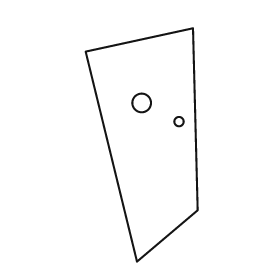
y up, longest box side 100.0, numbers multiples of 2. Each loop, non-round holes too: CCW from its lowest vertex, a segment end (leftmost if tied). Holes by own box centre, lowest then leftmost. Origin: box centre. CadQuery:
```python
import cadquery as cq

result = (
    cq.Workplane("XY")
    .moveTo(-2.0, -50.0)
    .lineTo(24.0, -28.0)
    .lineTo(22.0, 50.0)
    .lineTo(-24.0, 40.0)
    .close()
    .moveTo(16.0, 10.0)
    .circle(2.0)
    .moveTo(0.0, 18.0)
    .circle(4.0)
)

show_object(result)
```